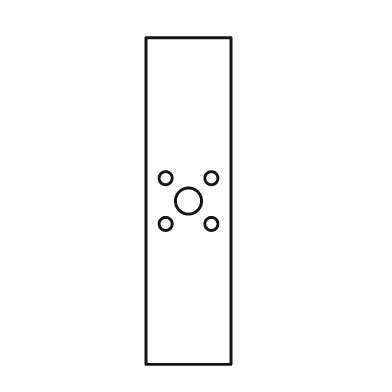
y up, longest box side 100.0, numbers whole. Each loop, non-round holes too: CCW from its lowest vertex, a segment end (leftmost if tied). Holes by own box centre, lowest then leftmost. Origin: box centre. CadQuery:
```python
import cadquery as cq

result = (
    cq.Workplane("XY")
    .moveTo(-13.0, -50.0)
    .lineTo(13.0, -50.0)
    .lineTo(13.0, 50.0)
    .lineTo(-13.0, 50.0)
    .close()
    .moveTo(-7.0, -7.0)
    .circle(2.0)
    .moveTo(7.0, -7.0)
    .circle(2.0)
    .moveTo(0.0, 0.0)
    .circle(4.0)
    .moveTo(-7.0, 7.0)
    .circle(2.0)
    .moveTo(7.0, 7.0)
    .circle(2.0)
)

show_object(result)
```